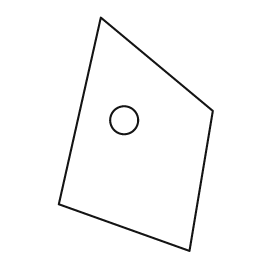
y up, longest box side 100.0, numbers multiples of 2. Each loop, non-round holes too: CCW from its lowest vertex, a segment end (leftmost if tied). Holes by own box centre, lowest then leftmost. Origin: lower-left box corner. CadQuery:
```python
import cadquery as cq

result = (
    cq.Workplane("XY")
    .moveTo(56.0, 0.0)
    .lineTo(66.0, 60.0)
    .lineTo(18.0, 100.0)
    .lineTo(0.0, 20.0)
    .close()
    .moveTo(28.0, 56.0)
    .circle(6.0)
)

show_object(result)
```